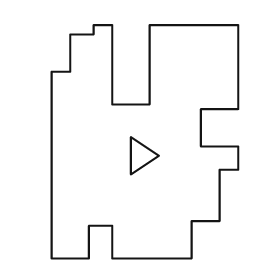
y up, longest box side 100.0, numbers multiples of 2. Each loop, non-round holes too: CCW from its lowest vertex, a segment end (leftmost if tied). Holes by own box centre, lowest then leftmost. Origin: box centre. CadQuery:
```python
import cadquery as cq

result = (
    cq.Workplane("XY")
    .moveTo(-40.0, -50.0)
    .lineTo(-24.0, -50.0)
    .lineTo(-24.0, -36.0)
    .lineTo(-14.0, -36.0)
    .lineTo(-14.0, -50.0)
    .lineTo(20.0, -50.0)
    .lineTo(20.0, -34.0)
    .lineTo(32.0, -34.0)
    .lineTo(32.0, -12.0)
    .lineTo(40.0, -12.0)
    .lineTo(40.0, -2.0)
    .lineTo(24.0, -2.0)
    .lineTo(24.0, 14.0)
    .lineTo(40.0, 14.0)
    .lineTo(40.0, 50.0)
    .lineTo(2.0, 50.0)
    .lineTo(2.0, 16.0)
    .lineTo(-14.0, 16.0)
    .lineTo(-14.0, 50.0)
    .lineTo(-22.0, 50.0)
    .lineTo(-22.0, 46.0)
    .lineTo(-32.0, 46.0)
    .lineTo(-32.0, 30.0)
    .lineTo(-40.0, 30.0)
    .close()
    .moveTo(-6.0, -14.0)
    .lineTo(6.0, -6.0)
    .lineTo(-6.0, 2.0)
    .close()
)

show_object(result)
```